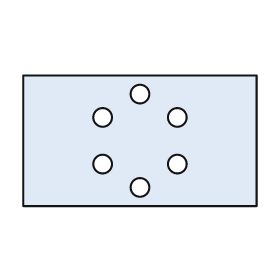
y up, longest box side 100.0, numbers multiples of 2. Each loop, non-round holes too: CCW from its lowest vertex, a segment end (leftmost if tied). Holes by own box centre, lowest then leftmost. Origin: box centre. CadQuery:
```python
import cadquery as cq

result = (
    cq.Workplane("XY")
    .moveTo(-50.0, -28.0)
    .lineTo(50.0, -28.0)
    .lineTo(50.0, 28.0)
    .lineTo(-50.0, 28.0)
    .close()
    .moveTo(0.0, -20.0)
    .circle(4.0)
    .moveTo(-16.0, -10.0)
    .circle(4.0)
    .moveTo(16.0, -10.0)
    .circle(4.0)
    .moveTo(-16.0, 10.0)
    .circle(4.0)
    .moveTo(16.0, 10.0)
    .circle(4.0)
    .moveTo(0.0, 20.0)
    .circle(4.0)
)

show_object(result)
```